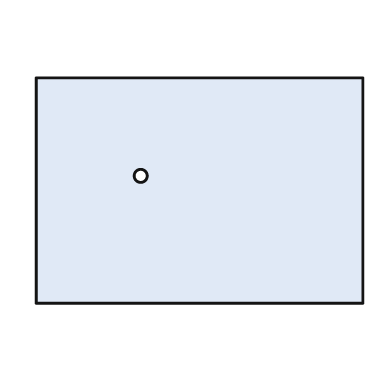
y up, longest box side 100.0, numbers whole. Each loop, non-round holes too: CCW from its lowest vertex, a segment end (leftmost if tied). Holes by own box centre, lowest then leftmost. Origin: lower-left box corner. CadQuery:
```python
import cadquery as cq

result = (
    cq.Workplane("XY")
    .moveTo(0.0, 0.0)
    .lineTo(100.0, 0.0)
    .lineTo(100.0, 69.0)
    .lineTo(0.0, 69.0)
    .close()
    .moveTo(32.0, 39.0)
    .circle(2.0)
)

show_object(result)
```